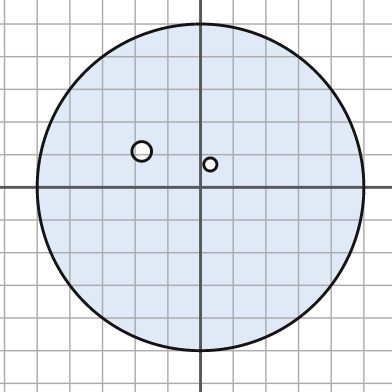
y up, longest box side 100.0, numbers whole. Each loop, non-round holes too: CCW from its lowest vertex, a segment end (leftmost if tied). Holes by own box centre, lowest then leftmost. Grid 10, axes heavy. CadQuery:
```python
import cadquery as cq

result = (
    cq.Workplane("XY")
    .moveTo(0.0, 0.0)
    .circle(50.0)
    .moveTo(3.0, 7.0)
    .circle(2.0)
    .moveTo(-18.0, 11.0)
    .circle(3.0)
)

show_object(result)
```